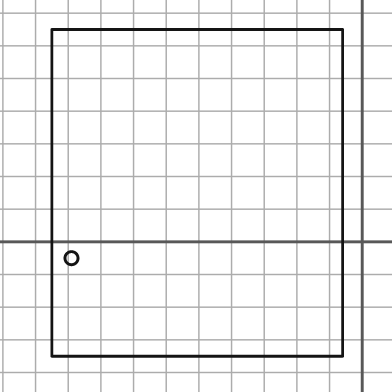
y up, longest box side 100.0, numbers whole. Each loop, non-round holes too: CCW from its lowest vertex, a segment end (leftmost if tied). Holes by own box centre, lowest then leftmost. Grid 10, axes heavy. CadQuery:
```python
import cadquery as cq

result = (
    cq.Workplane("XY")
    .moveTo(-95.0, -35.0)
    .lineTo(-6.0, -35.0)
    .lineTo(-6.0, 65.0)
    .lineTo(-95.0, 65.0)
    .close()
    .moveTo(-89.0, -5.0)
    .circle(2.0)
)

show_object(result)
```